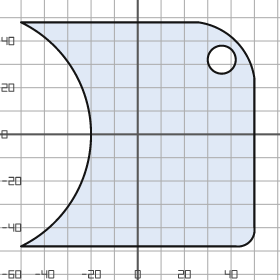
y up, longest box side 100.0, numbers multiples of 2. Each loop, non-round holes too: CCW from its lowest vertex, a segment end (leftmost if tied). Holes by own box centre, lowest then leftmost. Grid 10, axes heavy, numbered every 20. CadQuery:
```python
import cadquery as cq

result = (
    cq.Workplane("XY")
    .moveTo(-50.0, -48.0)
    .lineTo(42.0, -48.0)
    .threePointArc((48.0, -46.0), (50.0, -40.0))
    .lineTo(50.0, 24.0)
    .threePointArc((42.0, 40.0), (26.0, 48.0))
    .lineTo(-50.0, 48.0)
    .threePointArc((-20.0, 0.0), (-50.0, -48.0))
    .close()
    .moveTo(36.0, 32.0)
    .circle(6.0)
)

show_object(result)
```